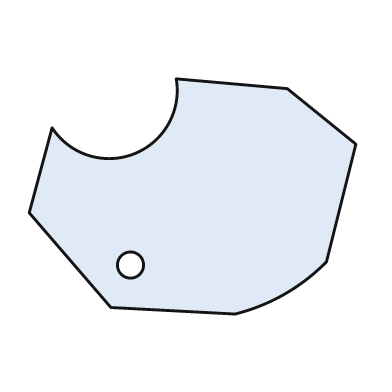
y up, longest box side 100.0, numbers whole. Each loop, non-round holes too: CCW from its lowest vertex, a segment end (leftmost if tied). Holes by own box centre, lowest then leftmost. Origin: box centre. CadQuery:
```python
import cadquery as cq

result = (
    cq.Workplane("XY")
    .moveTo(13.0, -36.0)
    .threePointArc((28.0, -30.0), (41.0, -20.0))
    .lineTo(50.0, 16.0)
    .lineTo(29.0, 33.0)
    .lineTo(-5.0, 36.0)
    .threePointArc((-18.0, 13.0), (-43.0, 21.0))
    .lineTo(-50.0, -5.0)
    .lineTo(-25.0, -34.0)
    .close()
    .moveTo(-19.0, -21.0)
    .circle(4.0)
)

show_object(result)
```